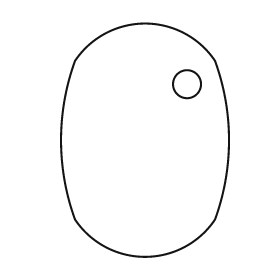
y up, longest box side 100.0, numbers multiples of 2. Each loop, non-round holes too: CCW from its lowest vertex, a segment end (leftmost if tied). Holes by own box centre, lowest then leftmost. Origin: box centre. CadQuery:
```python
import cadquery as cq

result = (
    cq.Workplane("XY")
    .moveTo(-30.0, -34.0)
    .threePointArc((0.0, -50.0), (30.0, -34.0))
    .threePointArc((36.0, 0.0), (30.0, 34.0))
    .threePointArc((0.0, 50.0), (-30.0, 34.0))
    .threePointArc((-36.0, 0.0), (-30.0, -34.0))
    .close()
    .moveTo(18.0, 24.0)
    .circle(6.0)
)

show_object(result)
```